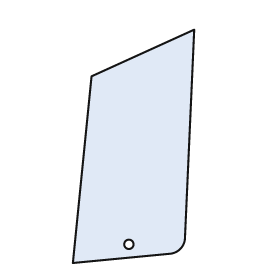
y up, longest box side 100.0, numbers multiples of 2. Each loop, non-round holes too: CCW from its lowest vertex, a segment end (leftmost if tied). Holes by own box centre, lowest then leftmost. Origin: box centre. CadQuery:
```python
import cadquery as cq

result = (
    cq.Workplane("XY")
    .moveTo(-26.0, -50.0)
    .lineTo(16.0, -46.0)
    .threePointArc((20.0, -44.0), (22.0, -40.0))
    .lineTo(26.0, 50.0)
    .lineTo(-18.0, 30.0)
    .close()
    .moveTo(-2.0, -42.0)
    .circle(2.0)
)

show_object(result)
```